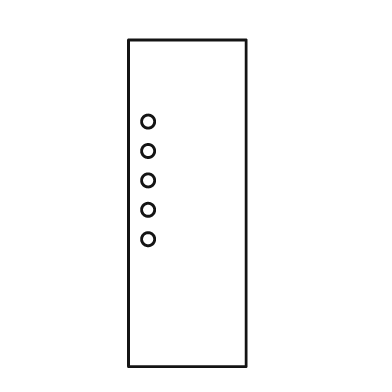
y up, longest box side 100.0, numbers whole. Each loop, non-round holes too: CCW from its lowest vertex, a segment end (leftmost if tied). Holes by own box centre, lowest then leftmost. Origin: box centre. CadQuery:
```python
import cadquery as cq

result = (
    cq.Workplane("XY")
    .moveTo(-18.0, -50.0)
    .lineTo(18.0, -50.0)
    .lineTo(18.0, 50.0)
    .lineTo(-18.0, 50.0)
    .close()
    .moveTo(-12.0, -11.0)
    .circle(2.0)
    .moveTo(-12.0, -2.0)
    .circle(2.0)
    .moveTo(-12.0, 7.0)
    .circle(2.0)
    .moveTo(-12.0, 16.0)
    .circle(2.0)
    .moveTo(-12.0, 25.0)
    .circle(2.0)
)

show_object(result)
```